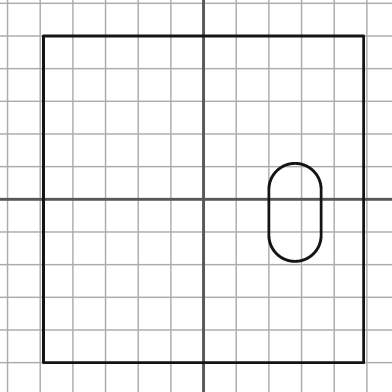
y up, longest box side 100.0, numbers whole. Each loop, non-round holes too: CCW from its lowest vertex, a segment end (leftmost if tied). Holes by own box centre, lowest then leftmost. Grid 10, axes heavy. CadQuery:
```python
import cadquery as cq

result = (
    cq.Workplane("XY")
    .moveTo(-49.0, -50.0)
    .lineTo(49.0, -50.0)
    .lineTo(49.0, 50.0)
    .lineTo(-49.0, 50.0)
    .close()
    .moveTo(20.0, -11.0)
    .threePointArc((28.0, -19.0), (36.0, -11.0))
    .lineTo(36.0, 3.0)
    .threePointArc((28.0, 11.0), (20.0, 3.0))
    .close()
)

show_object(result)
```